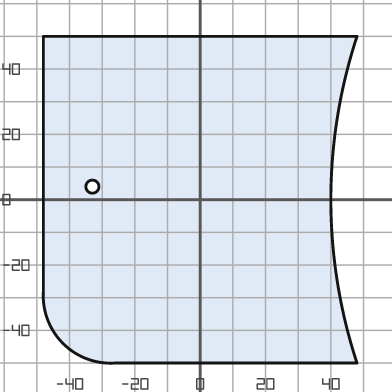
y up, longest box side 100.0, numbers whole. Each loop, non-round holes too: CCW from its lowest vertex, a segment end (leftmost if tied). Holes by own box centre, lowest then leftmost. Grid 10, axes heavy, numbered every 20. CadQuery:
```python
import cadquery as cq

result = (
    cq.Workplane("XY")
    .moveTo(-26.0, -50.0)
    .lineTo(48.0, -50.0)
    .threePointArc((40.0, 0.0), (48.0, 50.0))
    .lineTo(-48.0, 50.0)
    .lineTo(-48.0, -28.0)
    .threePointArc((-42.0, -44.0), (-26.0, -50.0))
    .close()
    .moveTo(-33.0, 4.0)
    .circle(2.0)
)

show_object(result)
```